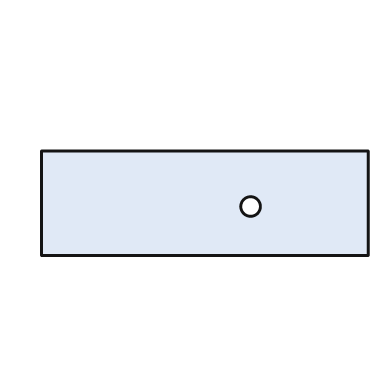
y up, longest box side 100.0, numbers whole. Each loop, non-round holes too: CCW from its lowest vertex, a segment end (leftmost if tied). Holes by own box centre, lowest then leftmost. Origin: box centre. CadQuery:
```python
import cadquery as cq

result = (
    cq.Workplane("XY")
    .moveTo(-50.0, -16.0)
    .lineTo(50.0, -16.0)
    .lineTo(50.0, 16.0)
    .lineTo(-50.0, 16.0)
    .close()
    .moveTo(14.0, -1.0)
    .circle(3.0)
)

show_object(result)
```